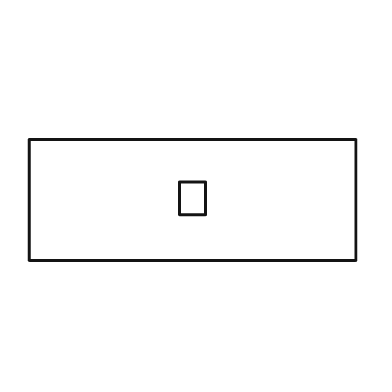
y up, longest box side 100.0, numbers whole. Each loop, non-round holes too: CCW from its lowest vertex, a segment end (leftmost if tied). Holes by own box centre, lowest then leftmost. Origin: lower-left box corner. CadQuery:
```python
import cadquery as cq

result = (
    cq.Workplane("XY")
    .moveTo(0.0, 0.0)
    .lineTo(100.0, 0.0)
    .lineTo(100.0, 37.0)
    .lineTo(0.0, 37.0)
    .close()
    .moveTo(46.0, 14.0)
    .lineTo(54.0, 14.0)
    .lineTo(54.0, 24.0)
    .lineTo(46.0, 24.0)
    .close()
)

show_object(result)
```